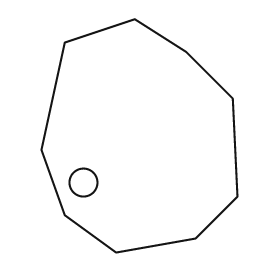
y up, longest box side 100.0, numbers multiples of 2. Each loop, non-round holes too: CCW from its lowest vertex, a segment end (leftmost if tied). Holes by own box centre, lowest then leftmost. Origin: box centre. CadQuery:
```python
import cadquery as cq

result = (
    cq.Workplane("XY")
    .moveTo(-10.0, -50.0)
    .lineTo(24.0, -44.0)
    .lineTo(42.0, -26.0)
    .lineTo(40.0, 16.0)
    .lineTo(20.0, 36.0)
    .lineTo(-2.0, 50.0)
    .lineTo(-32.0, 40.0)
    .lineTo(-42.0, -6.0)
    .lineTo(-32.0, -34.0)
    .close()
    .moveTo(-24.0, -20.0)
    .circle(6.0)
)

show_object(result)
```